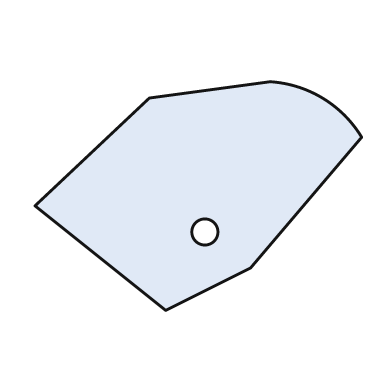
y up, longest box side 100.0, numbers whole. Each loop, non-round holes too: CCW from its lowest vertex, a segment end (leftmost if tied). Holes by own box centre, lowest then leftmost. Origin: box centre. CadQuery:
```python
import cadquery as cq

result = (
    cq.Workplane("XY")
    .moveTo(-10.0, -35.0)
    .lineTo(16.0, -22.0)
    .lineTo(50.0, 18.0)
    .threePointArc((38.0, 30.0), (22.0, 35.0))
    .lineTo(-15.0, 30.0)
    .lineTo(-50.0, -3.0)
    .close()
    .moveTo(2.0, -11.0)
    .circle(4.0)
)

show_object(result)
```